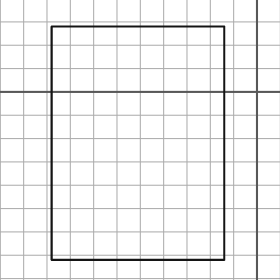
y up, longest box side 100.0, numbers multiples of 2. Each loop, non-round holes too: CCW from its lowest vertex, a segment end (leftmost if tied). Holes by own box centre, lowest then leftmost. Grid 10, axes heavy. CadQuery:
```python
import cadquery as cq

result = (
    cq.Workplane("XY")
    .moveTo(-88.0, -72.0)
    .lineTo(-14.0, -72.0)
    .lineTo(-14.0, 28.0)
    .lineTo(-88.0, 28.0)
    .close()
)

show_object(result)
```